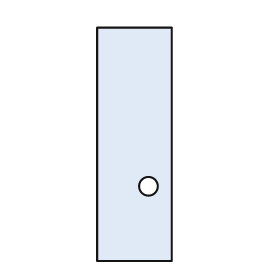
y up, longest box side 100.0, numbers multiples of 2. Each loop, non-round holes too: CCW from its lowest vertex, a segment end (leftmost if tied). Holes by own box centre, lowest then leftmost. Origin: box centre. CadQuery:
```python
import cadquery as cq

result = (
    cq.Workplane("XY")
    .moveTo(-16.0, -50.0)
    .lineTo(16.0, -50.0)
    .lineTo(16.0, 50.0)
    .lineTo(-16.0, 50.0)
    .close()
    .moveTo(6.0, -18.0)
    .circle(4.0)
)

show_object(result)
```